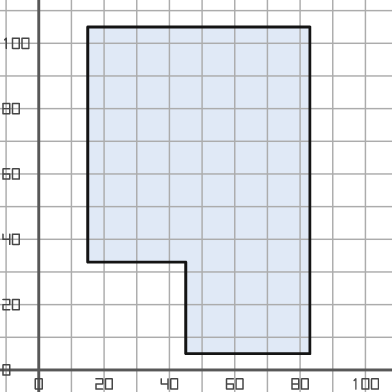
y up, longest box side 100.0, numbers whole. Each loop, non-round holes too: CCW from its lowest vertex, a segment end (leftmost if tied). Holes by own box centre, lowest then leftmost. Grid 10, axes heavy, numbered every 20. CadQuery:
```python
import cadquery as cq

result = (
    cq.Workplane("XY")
    .moveTo(45.0, 5.0)
    .lineTo(83.0, 5.0)
    .lineTo(83.0, 105.0)
    .lineTo(15.0, 105.0)
    .lineTo(15.0, 33.0)
    .lineTo(45.0, 33.0)
    .close()
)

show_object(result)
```